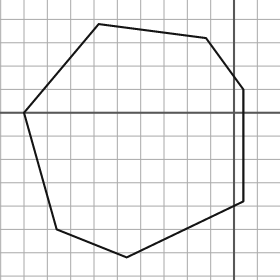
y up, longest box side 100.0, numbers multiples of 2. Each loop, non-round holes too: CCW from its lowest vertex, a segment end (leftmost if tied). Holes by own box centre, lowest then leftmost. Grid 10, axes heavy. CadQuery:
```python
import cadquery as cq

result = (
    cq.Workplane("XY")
    .moveTo(-46.0, -62.0)
    .lineTo(4.0, -38.0)
    .lineTo(4.0, 10.0)
    .lineTo(-12.0, 32.0)
    .lineTo(-58.0, 38.0)
    .lineTo(-90.0, 0.0)
    .lineTo(-76.0, -50.0)
    .close()
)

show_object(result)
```